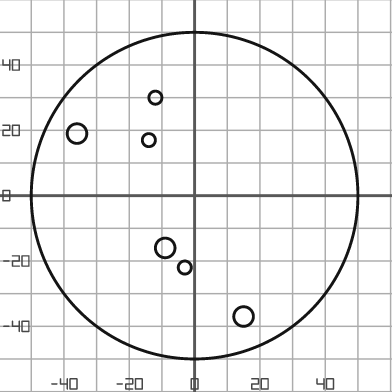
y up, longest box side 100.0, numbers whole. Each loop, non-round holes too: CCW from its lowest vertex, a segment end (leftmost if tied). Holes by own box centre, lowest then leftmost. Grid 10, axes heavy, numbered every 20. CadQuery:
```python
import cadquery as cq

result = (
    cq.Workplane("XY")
    .moveTo(0.0, 0.0)
    .circle(50.0)
    .moveTo(15.0, -37.0)
    .circle(3.0)
    .moveTo(-3.0, -22.0)
    .circle(2.0)
    .moveTo(-9.0, -16.0)
    .circle(3.0)
    .moveTo(-14.0, 17.0)
    .circle(2.0)
    .moveTo(-36.0, 19.0)
    .circle(3.0)
    .moveTo(-12.0, 30.0)
    .circle(2.0)
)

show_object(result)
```